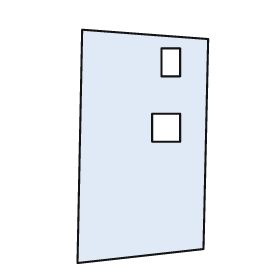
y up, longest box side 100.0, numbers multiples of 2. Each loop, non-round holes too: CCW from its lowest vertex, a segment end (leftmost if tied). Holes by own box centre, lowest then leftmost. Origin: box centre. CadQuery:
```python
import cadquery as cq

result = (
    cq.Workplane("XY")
    .moveTo(-28.0, -50.0)
    .lineTo(26.0, -44.0)
    .lineTo(28.0, 46.0)
    .lineTo(-26.0, 50.0)
    .close()
    .moveTo(4.0, 2.0)
    .lineTo(16.0, 2.0)
    .lineTo(16.0, 14.0)
    .lineTo(4.0, 14.0)
    .close()
    .moveTo(8.0, 30.0)
    .lineTo(16.0, 30.0)
    .lineTo(16.0, 42.0)
    .lineTo(8.0, 42.0)
    .close()
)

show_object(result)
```